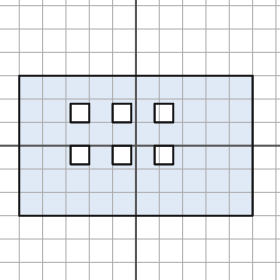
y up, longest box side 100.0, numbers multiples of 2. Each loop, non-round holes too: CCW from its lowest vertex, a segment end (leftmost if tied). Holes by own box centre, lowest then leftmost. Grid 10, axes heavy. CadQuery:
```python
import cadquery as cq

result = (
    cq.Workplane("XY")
    .moveTo(-50.0, -30.0)
    .lineTo(50.0, -30.0)
    .lineTo(50.0, 30.0)
    .lineTo(-50.0, 30.0)
    .close()
    .moveTo(-28.0, -8.0)
    .lineTo(-20.0, -8.0)
    .lineTo(-20.0, 0.0)
    .lineTo(-28.0, 0.0)
    .close()
    .moveTo(-10.0, -8.0)
    .lineTo(-2.0, -8.0)
    .lineTo(-2.0, 0.0)
    .lineTo(-10.0, 0.0)
    .close()
    .moveTo(8.0, -8.0)
    .lineTo(16.0, -8.0)
    .lineTo(16.0, 0.0)
    .lineTo(8.0, 0.0)
    .close()
    .moveTo(-28.0, 10.0)
    .lineTo(-20.0, 10.0)
    .lineTo(-20.0, 18.0)
    .lineTo(-28.0, 18.0)
    .close()
    .moveTo(-10.0, 10.0)
    .lineTo(-2.0, 10.0)
    .lineTo(-2.0, 18.0)
    .lineTo(-10.0, 18.0)
    .close()
    .moveTo(8.0, 10.0)
    .lineTo(16.0, 10.0)
    .lineTo(16.0, 18.0)
    .lineTo(8.0, 18.0)
    .close()
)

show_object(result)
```